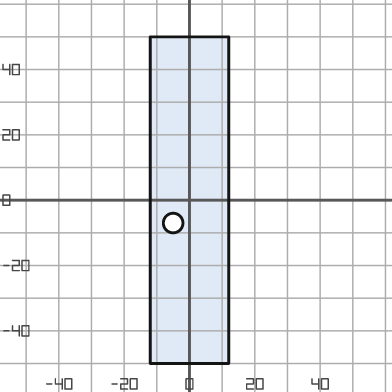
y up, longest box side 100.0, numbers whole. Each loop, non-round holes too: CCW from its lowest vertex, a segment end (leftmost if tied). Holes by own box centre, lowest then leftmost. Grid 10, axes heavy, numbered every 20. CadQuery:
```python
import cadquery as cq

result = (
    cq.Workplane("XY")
    .moveTo(-12.0, -50.0)
    .lineTo(12.0, -50.0)
    .lineTo(12.0, 50.0)
    .lineTo(-12.0, 50.0)
    .close()
    .moveTo(-5.0, -7.0)
    .circle(3.0)
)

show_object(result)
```